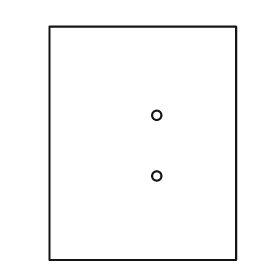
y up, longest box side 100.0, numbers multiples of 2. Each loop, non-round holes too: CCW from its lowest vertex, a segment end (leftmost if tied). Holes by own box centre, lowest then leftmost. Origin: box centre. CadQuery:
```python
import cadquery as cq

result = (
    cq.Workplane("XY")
    .moveTo(-40.0, -50.0)
    .lineTo(40.0, -50.0)
    .lineTo(40.0, 50.0)
    .lineTo(-40.0, 50.0)
    .close()
    .moveTo(6.0, -14.0)
    .circle(2.0)
    .moveTo(6.0, 12.0)
    .circle(2.0)
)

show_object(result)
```